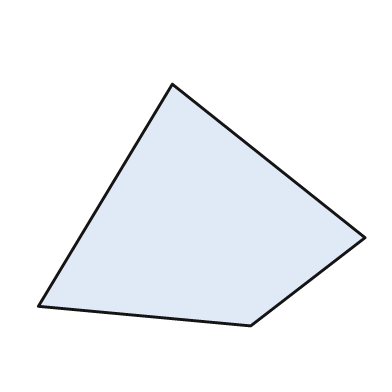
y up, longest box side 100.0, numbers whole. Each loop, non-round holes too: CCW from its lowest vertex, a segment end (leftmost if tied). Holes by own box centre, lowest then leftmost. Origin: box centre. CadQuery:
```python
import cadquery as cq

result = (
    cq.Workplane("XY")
    .moveTo(15.0, -37.0)
    .lineTo(50.0, -10.0)
    .lineTo(-9.0, 37.0)
    .lineTo(-50.0, -31.0)
    .close()
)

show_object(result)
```